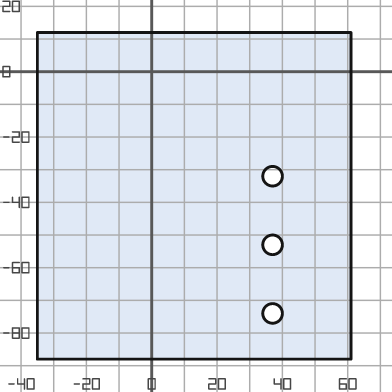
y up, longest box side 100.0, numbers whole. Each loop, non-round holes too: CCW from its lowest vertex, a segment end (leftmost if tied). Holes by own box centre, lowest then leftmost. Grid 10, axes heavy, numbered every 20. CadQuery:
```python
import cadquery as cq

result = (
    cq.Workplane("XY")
    .moveTo(-35.0, -88.0)
    .lineTo(61.0, -88.0)
    .lineTo(61.0, 12.0)
    .lineTo(-35.0, 12.0)
    .close()
    .moveTo(37.0, -74.0)
    .circle(3.0)
    .moveTo(37.0, -53.0)
    .circle(3.0)
    .moveTo(37.0, -32.0)
    .circle(3.0)
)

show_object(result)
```